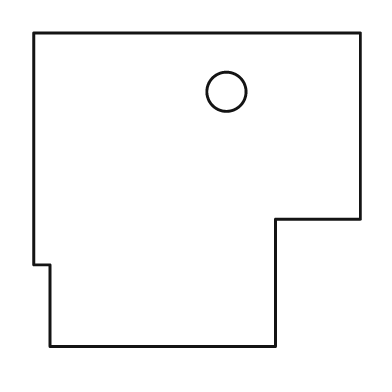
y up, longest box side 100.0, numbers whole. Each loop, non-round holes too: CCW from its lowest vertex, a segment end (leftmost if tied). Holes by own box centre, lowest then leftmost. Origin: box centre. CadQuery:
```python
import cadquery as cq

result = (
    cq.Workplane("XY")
    .moveTo(-45.0, -48.0)
    .lineTo(24.0, -48.0)
    .lineTo(24.0, -9.0)
    .lineTo(50.0, -9.0)
    .lineTo(50.0, 48.0)
    .lineTo(-50.0, 48.0)
    .lineTo(-50.0, -23.0)
    .lineTo(-45.0, -23.0)
    .close()
    .moveTo(9.0, 30.0)
    .circle(6.0)
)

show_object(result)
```